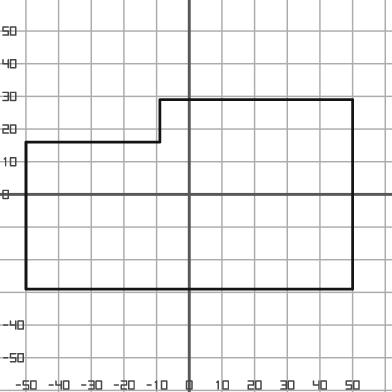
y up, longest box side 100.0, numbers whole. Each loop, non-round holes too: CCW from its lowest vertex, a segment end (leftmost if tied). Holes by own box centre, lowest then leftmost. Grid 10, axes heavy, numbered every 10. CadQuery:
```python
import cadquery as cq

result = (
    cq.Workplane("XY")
    .moveTo(-50.0, -29.0)
    .lineTo(50.0, -29.0)
    .lineTo(50.0, 29.0)
    .lineTo(-9.0, 29.0)
    .lineTo(-9.0, 16.0)
    .lineTo(-50.0, 16.0)
    .close()
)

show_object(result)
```